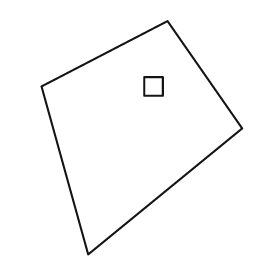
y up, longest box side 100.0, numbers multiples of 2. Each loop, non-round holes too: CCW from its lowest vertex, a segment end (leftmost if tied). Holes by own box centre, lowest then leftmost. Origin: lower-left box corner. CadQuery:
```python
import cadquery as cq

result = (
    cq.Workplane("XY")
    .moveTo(20.0, 0.0)
    .lineTo(86.0, 54.0)
    .lineTo(54.0, 100.0)
    .lineTo(0.0, 72.0)
    .close()
    .moveTo(44.0, 68.0)
    .lineTo(52.0, 68.0)
    .lineTo(52.0, 76.0)
    .lineTo(44.0, 76.0)
    .close()
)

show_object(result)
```